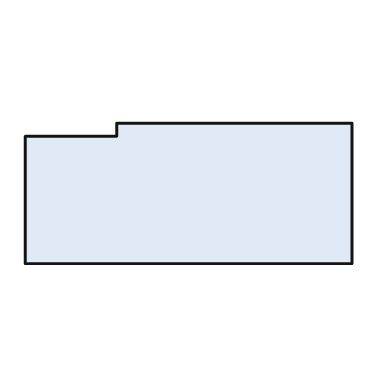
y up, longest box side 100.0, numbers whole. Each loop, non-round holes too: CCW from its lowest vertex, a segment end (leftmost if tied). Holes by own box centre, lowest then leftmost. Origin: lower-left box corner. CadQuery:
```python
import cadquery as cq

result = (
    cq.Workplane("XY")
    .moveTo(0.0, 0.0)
    .lineTo(100.0, 0.0)
    .lineTo(100.0, 43.0)
    .lineTo(28.0, 43.0)
    .lineTo(28.0, 39.0)
    .lineTo(0.0, 39.0)
    .close()
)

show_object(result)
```